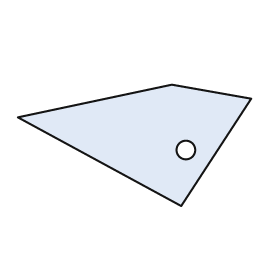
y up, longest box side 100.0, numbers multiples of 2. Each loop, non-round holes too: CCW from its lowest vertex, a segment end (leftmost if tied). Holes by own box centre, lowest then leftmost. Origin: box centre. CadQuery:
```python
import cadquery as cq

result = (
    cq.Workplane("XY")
    .moveTo(20.0, -26.0)
    .lineTo(50.0, 20.0)
    .lineTo(16.0, 26.0)
    .lineTo(-50.0, 12.0)
    .close()
    .moveTo(22.0, -2.0)
    .circle(4.0)
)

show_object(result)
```